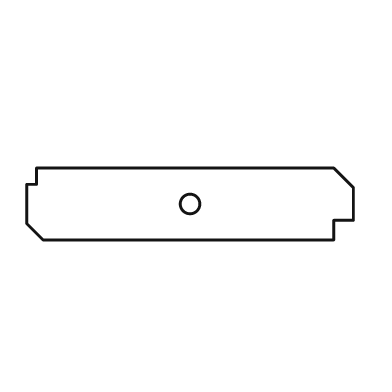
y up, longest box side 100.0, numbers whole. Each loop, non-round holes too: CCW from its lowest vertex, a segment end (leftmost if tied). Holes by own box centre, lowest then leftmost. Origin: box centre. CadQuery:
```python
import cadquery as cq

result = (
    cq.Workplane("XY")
    .moveTo(-45.0, -11.0)
    .lineTo(44.0, -11.0)
    .lineTo(44.0, -5.0)
    .lineTo(50.0, -5.0)
    .lineTo(50.0, 5.0)
    .lineTo(44.0, 11.0)
    .lineTo(-47.0, 11.0)
    .lineTo(-47.0, 6.0)
    .lineTo(-50.0, 6.0)
    .lineTo(-50.0, -6.0)
    .close()
    .moveTo(0.0, 0.0)
    .circle(3.0)
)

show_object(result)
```